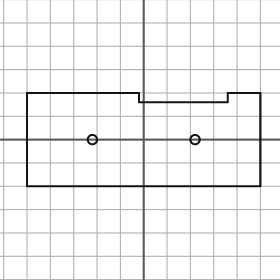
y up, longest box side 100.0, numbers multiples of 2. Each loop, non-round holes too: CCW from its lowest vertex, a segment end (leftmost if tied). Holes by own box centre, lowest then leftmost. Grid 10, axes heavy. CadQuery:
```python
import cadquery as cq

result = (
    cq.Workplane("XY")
    .moveTo(-50.0, -20.0)
    .lineTo(50.0, -20.0)
    .lineTo(50.0, 20.0)
    .lineTo(36.0, 20.0)
    .lineTo(36.0, 16.0)
    .lineTo(-2.0, 16.0)
    .lineTo(-2.0, 20.0)
    .lineTo(-50.0, 20.0)
    .close()
    .moveTo(-22.0, 0.0)
    .circle(2.0)
    .moveTo(22.0, 0.0)
    .circle(2.0)
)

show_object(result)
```